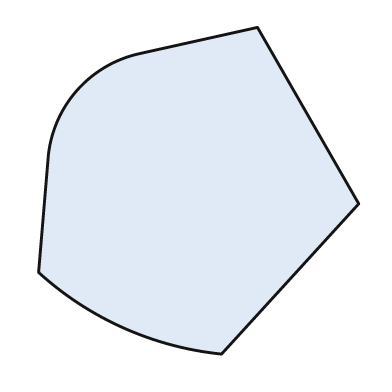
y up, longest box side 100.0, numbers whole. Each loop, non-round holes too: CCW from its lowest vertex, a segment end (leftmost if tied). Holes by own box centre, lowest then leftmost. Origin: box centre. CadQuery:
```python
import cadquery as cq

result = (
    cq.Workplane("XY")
    .moveTo(7.0, -50.0)
    .lineTo(49.0, -4.0)
    .lineTo(18.0, 50.0)
    .lineTo(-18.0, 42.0)
    .threePointArc((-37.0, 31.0), (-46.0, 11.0))
    .lineTo(-49.0, -25.0)
    .threePointArc((-23.0, -42.0), (7.0, -50.0))
    .close()
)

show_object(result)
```